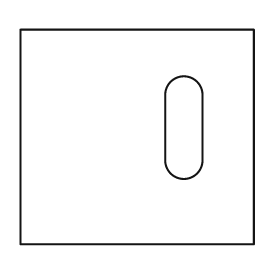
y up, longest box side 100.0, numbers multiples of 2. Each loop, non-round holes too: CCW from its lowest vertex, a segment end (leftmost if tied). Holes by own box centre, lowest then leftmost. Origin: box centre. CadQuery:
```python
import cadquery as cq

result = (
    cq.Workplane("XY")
    .moveTo(-50.0, -46.0)
    .lineTo(50.0, -46.0)
    .lineTo(50.0, 46.0)
    .lineTo(-50.0, 46.0)
    .close()
    .moveTo(12.0, -10.0)
    .threePointArc((20.0, -18.0), (28.0, -10.0))
    .lineTo(28.0, 18.0)
    .threePointArc((20.0, 26.0), (12.0, 18.0))
    .close()
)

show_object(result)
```